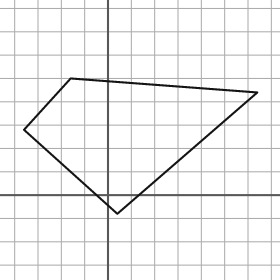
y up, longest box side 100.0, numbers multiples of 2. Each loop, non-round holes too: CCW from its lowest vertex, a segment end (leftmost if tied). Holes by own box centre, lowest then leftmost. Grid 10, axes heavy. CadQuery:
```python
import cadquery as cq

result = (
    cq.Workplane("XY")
    .moveTo(4.0, -8.0)
    .lineTo(64.0, 44.0)
    .lineTo(-16.0, 50.0)
    .lineTo(-36.0, 28.0)
    .close()
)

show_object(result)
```